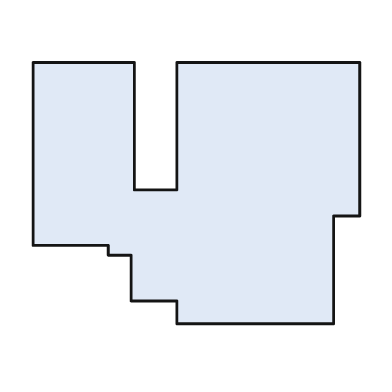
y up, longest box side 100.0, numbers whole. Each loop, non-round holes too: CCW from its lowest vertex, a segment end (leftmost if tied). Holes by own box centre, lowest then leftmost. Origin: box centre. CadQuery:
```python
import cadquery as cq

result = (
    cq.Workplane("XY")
    .moveTo(-6.0, -40.0)
    .lineTo(42.0, -40.0)
    .lineTo(42.0, -7.0)
    .lineTo(50.0, -7.0)
    .lineTo(50.0, 40.0)
    .lineTo(-6.0, 40.0)
    .lineTo(-6.0, 1.0)
    .lineTo(-19.0, 1.0)
    .lineTo(-19.0, 40.0)
    .lineTo(-50.0, 40.0)
    .lineTo(-50.0, -16.0)
    .lineTo(-27.0, -16.0)
    .lineTo(-27.0, -19.0)
    .lineTo(-20.0, -19.0)
    .lineTo(-20.0, -33.0)
    .lineTo(-6.0, -33.0)
    .close()
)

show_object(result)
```